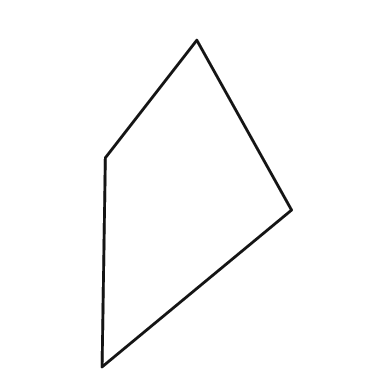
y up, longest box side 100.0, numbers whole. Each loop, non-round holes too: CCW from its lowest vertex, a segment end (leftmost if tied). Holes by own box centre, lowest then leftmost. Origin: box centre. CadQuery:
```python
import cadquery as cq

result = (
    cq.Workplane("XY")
    .moveTo(-29.0, -50.0)
    .lineTo(29.0, -2.0)
    .lineTo(0.0, 50.0)
    .lineTo(-28.0, 14.0)
    .close()
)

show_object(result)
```